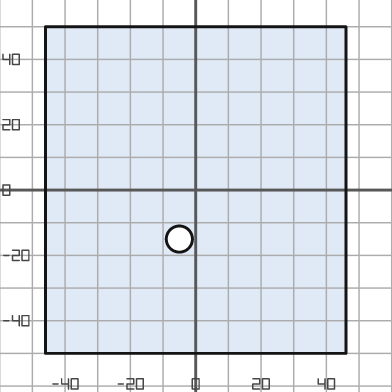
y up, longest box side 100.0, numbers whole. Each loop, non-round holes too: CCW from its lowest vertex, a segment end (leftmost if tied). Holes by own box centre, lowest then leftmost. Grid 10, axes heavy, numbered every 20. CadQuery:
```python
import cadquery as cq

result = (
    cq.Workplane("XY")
    .moveTo(-46.0, -50.0)
    .lineTo(46.0, -50.0)
    .lineTo(46.0, 50.0)
    .lineTo(-46.0, 50.0)
    .close()
    .moveTo(-5.0, -15.0)
    .circle(4.0)
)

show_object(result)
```